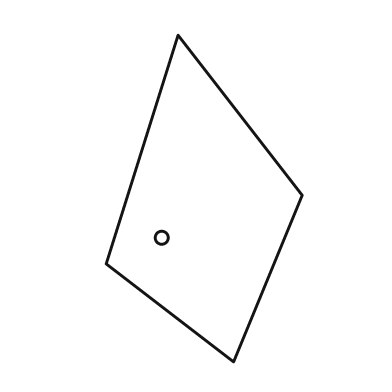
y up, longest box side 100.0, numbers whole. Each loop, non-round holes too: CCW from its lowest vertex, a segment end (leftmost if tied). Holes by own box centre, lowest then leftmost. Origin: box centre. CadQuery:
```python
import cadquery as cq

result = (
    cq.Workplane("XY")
    .moveTo(9.0, -50.0)
    .lineTo(30.0, 1.0)
    .lineTo(-8.0, 50.0)
    .lineTo(-30.0, -20.0)
    .close()
    .moveTo(-13.0, -12.0)
    .circle(2.0)
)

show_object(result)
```